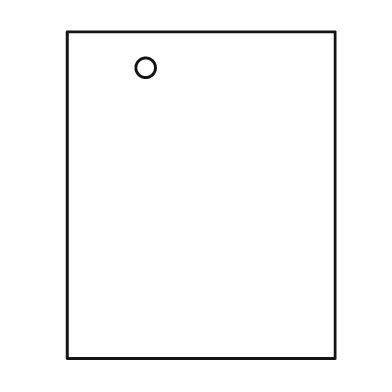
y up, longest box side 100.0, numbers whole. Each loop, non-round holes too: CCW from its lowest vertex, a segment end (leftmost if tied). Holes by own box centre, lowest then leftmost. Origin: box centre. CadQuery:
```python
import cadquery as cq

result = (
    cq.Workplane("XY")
    .moveTo(-41.0, -50.0)
    .lineTo(41.0, -50.0)
    .lineTo(41.0, 50.0)
    .lineTo(-41.0, 50.0)
    .close()
    .moveTo(-17.0, 39.0)
    .circle(3.0)
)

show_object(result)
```